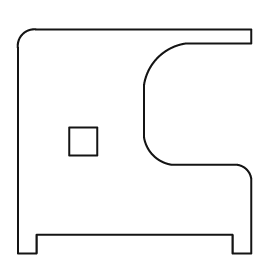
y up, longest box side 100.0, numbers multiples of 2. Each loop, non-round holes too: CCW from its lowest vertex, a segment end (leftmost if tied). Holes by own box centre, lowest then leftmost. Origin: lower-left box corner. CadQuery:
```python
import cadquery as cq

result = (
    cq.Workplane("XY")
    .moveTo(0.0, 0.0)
    .lineTo(8.0, 0.0)
    .lineTo(8.0, 8.0)
    .lineTo(92.0, 8.0)
    .lineTo(92.0, 0.0)
    .lineTo(100.0, 0.0)
    .lineTo(100.0, 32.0)
    .threePointArc((98.0, 36.0), (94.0, 38.0))
    .lineTo(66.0, 38.0)
    .threePointArc((58.0, 42.0), (54.0, 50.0))
    .lineTo(54.0, 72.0)
    .threePointArc((60.0, 84.0), (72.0, 90.0))
    .lineTo(100.0, 90.0)
    .lineTo(100.0, 96.0)
    .lineTo(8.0, 96.0)
    .threePointArc((2.0, 94.0), (0.0, 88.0))
    .close()
    .moveTo(22.0, 42.0)
    .lineTo(34.0, 42.0)
    .lineTo(34.0, 54.0)
    .lineTo(22.0, 54.0)
    .close()
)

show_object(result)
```